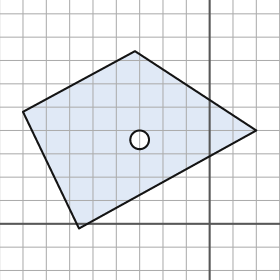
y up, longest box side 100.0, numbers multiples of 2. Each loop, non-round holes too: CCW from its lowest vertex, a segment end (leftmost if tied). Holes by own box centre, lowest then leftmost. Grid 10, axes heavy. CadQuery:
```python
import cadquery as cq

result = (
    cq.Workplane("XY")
    .moveTo(-56.0, -2.0)
    .lineTo(20.0, 40.0)
    .lineTo(-32.0, 74.0)
    .lineTo(-80.0, 48.0)
    .close()
    .moveTo(-30.0, 36.0)
    .circle(4.0)
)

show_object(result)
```